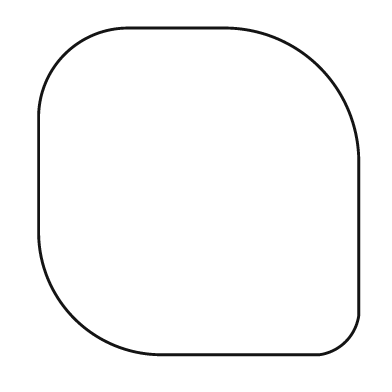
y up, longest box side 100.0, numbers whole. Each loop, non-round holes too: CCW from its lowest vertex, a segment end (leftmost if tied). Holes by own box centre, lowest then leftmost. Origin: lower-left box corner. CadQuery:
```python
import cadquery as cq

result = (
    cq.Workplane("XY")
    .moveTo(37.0, 0.0)
    .lineTo(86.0, 0.0)
    .threePointArc((94.0, 4.0), (98.0, 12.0))
    .lineTo(98.0, 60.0)
    .threePointArc((86.0, 88.0), (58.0, 100.0))
    .lineTo(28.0, 100.0)
    .threePointArc((8.0, 92.0), (0.0, 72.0))
    .lineTo(0.0, 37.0)
    .threePointArc((11.0, 11.0), (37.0, 0.0))
    .close()
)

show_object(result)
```